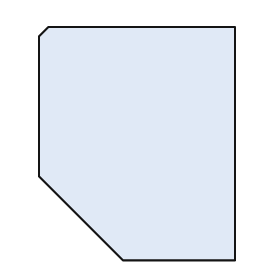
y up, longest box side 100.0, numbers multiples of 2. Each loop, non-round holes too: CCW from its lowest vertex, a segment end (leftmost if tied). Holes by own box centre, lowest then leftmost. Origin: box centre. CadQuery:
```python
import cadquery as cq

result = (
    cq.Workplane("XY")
    .moveTo(-6.0, -50.0)
    .lineTo(42.0, -50.0)
    .lineTo(42.0, 50.0)
    .lineTo(-38.0, 50.0)
    .lineTo(-42.0, 46.0)
    .lineTo(-42.0, -14.0)
    .close()
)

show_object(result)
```